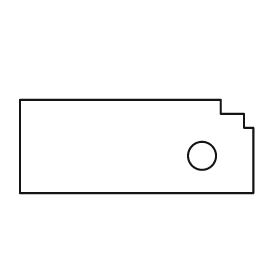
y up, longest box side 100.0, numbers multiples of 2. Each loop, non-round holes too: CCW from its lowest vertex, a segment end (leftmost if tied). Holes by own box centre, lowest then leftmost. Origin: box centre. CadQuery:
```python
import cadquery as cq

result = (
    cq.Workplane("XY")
    .moveTo(-50.0, -20.0)
    .lineTo(50.0, -20.0)
    .lineTo(50.0, 8.0)
    .lineTo(46.0, 8.0)
    .lineTo(46.0, 14.0)
    .lineTo(36.0, 14.0)
    .lineTo(36.0, 20.0)
    .lineTo(-50.0, 20.0)
    .close()
    .moveTo(28.0, -4.0)
    .circle(6.0)
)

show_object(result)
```